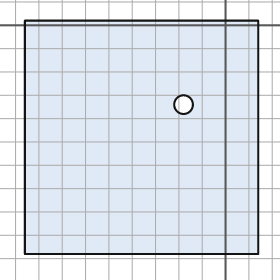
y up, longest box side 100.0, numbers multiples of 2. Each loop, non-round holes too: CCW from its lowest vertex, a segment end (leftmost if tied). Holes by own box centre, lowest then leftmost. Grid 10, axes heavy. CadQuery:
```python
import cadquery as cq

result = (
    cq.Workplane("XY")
    .moveTo(-86.0, -98.0)
    .lineTo(14.0, -98.0)
    .lineTo(14.0, 2.0)
    .lineTo(-86.0, 2.0)
    .close()
    .moveTo(-18.0, -34.0)
    .circle(4.0)
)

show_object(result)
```